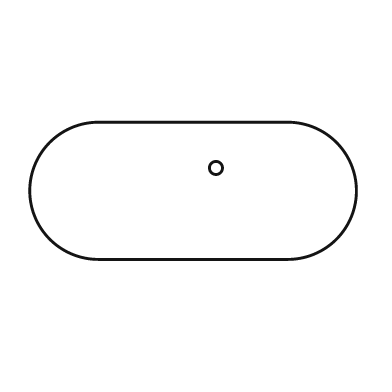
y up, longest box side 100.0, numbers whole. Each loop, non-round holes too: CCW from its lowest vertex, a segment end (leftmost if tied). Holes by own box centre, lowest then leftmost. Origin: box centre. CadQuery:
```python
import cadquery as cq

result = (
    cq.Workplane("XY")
    .moveTo(-29.0, -21.0)
    .lineTo(29.0, -21.0)
    .threePointArc((50.0, 0.0), (29.0, 21.0))
    .lineTo(-29.0, 21.0)
    .threePointArc((-50.0, 0.0), (-29.0, -21.0))
    .close()
    .moveTo(7.0, 7.0)
    .circle(2.0)
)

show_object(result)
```